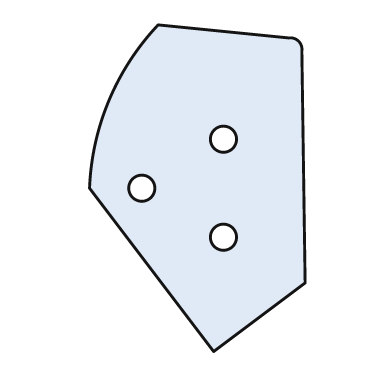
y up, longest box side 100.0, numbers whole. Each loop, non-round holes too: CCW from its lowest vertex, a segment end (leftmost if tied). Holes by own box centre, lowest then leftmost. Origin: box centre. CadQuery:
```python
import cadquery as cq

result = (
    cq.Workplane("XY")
    .moveTo(5.0, -50.0)
    .lineTo(33.0, -29.0)
    .lineTo(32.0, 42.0)
    .threePointArc((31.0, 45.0), (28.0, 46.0))
    .lineTo(-12.0, 50.0)
    .threePointArc((-27.0, 27.0), (-33.0, 0.0))
    .close()
    .moveTo(8.0, -15.0)
    .circle(4.0)
    .moveTo(-17.0, 0.0)
    .circle(4.0)
    .moveTo(8.0, 15.0)
    .circle(4.0)
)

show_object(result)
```